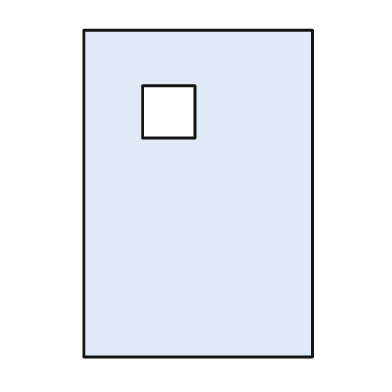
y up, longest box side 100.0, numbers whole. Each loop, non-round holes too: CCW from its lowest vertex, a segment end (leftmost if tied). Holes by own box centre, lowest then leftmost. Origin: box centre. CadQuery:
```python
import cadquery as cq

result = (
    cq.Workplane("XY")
    .moveTo(-35.0, -50.0)
    .lineTo(35.0, -50.0)
    .lineTo(35.0, 50.0)
    .lineTo(-35.0, 50.0)
    .close()
    .moveTo(-17.0, 17.0)
    .lineTo(-1.0, 17.0)
    .lineTo(-1.0, 33.0)
    .lineTo(-17.0, 33.0)
    .close()
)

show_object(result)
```